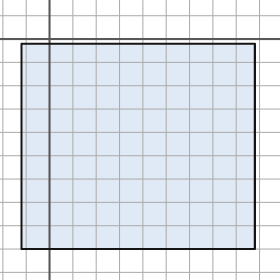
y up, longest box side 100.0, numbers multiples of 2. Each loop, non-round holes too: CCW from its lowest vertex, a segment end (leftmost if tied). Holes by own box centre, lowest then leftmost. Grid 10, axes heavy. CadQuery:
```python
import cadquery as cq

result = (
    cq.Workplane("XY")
    .moveTo(-12.0, -90.0)
    .lineTo(88.0, -90.0)
    .lineTo(88.0, -2.0)
    .lineTo(-12.0, -2.0)
    .close()
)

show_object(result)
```